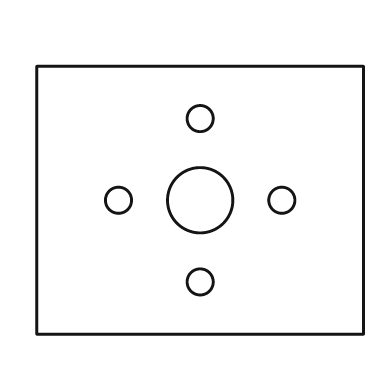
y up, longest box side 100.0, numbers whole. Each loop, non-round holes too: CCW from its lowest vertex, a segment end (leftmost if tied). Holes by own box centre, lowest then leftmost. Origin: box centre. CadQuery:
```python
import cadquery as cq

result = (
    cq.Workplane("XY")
    .moveTo(-50.0, -41.0)
    .lineTo(50.0, -41.0)
    .lineTo(50.0, 41.0)
    .lineTo(-50.0, 41.0)
    .close()
    .moveTo(0.0, -25.0)
    .circle(4.0)
    .moveTo(-25.0, 0.0)
    .circle(4.0)
    .moveTo(0.0, 0.0)
    .circle(10.0)
    .moveTo(25.0, 0.0)
    .circle(4.0)
    .moveTo(0.0, 25.0)
    .circle(4.0)
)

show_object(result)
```